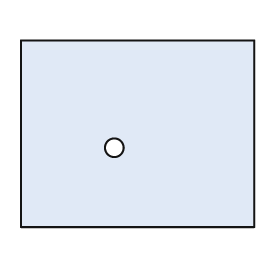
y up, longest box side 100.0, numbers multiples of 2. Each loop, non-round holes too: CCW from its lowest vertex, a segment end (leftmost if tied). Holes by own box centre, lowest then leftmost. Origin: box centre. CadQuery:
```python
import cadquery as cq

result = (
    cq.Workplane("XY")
    .moveTo(-50.0, -40.0)
    .lineTo(50.0, -40.0)
    .lineTo(50.0, 40.0)
    .lineTo(-50.0, 40.0)
    .close()
    .moveTo(-10.0, -6.0)
    .circle(4.0)
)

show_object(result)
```